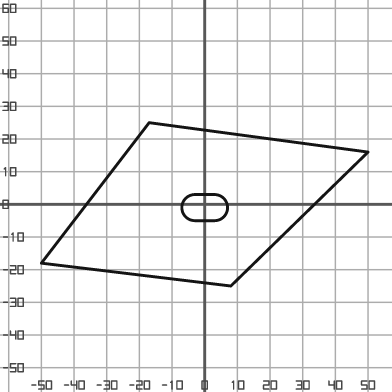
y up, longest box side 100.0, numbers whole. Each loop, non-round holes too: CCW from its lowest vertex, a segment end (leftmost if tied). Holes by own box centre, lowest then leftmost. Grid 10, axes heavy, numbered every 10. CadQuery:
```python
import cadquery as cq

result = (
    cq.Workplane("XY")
    .moveTo(8.0, -25.0)
    .lineTo(50.0, 16.0)
    .lineTo(-17.0, 25.0)
    .lineTo(-50.0, -18.0)
    .close()
    .moveTo(-3.0, -5.0)
    .lineTo(3.0, -5.0)
    .threePointArc((7.0, -1.0), (3.0, 3.0))
    .lineTo(-3.0, 3.0)
    .threePointArc((-7.0, -1.0), (-3.0, -5.0))
    .close()
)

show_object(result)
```